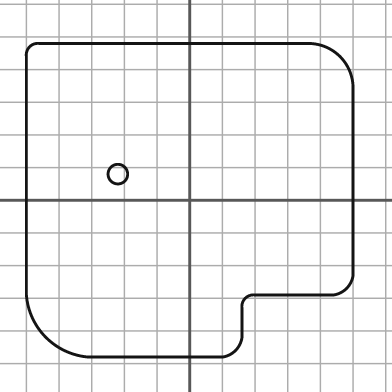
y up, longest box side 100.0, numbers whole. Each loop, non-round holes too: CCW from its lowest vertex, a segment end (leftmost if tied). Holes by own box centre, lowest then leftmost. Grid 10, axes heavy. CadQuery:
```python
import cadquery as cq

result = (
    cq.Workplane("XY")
    .moveTo(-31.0, -48.0)
    .lineTo(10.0, -48.0)
    .threePointArc((14.0, -46.0), (16.0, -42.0))
    .lineTo(16.0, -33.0)
    .threePointArc((17.0, -30.0), (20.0, -29.0))
    .lineTo(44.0, -29.0)
    .threePointArc((48.0, -27.0), (50.0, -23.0))
    .lineTo(50.0, 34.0)
    .threePointArc((46.0, 44.0), (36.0, 48.0))
    .lineTo(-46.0, 48.0)
    .threePointArc((-49.0, 47.0), (-50.0, 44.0))
    .lineTo(-50.0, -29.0)
    .threePointArc((-44.0, -42.0), (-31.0, -48.0))
    .close()
    .moveTo(-22.0, 8.0)
    .circle(3.0)
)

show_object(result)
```